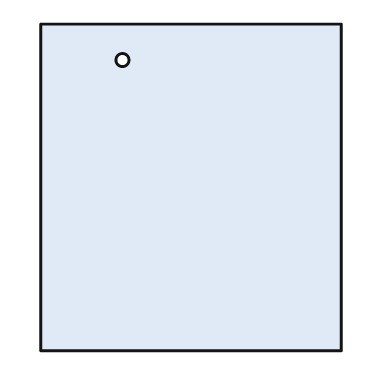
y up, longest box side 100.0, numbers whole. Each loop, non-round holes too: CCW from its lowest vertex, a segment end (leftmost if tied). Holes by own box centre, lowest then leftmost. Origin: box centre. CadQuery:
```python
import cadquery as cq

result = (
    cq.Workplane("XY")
    .moveTo(-46.0, -50.0)
    .lineTo(46.0, -50.0)
    .lineTo(46.0, 50.0)
    .lineTo(-46.0, 50.0)
    .close()
    .moveTo(-21.0, 39.0)
    .circle(2.0)
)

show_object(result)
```